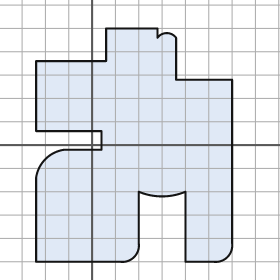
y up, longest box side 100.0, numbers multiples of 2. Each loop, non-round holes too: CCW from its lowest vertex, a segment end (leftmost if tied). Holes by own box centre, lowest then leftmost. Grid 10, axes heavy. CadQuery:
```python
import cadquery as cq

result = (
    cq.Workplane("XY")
    .moveTo(-24.0, -50.0)
    .lineTo(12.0, -50.0)
    .threePointArc((18.0, -48.0), (20.0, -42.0))
    .lineTo(20.0, -20.0)
    .threePointArc((30.0, -22.0), (40.0, -20.0))
    .lineTo(40.0, -50.0)
    .lineTo(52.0, -50.0)
    .threePointArc((58.0, -48.0), (60.0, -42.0))
    .lineTo(60.0, 28.0)
    .lineTo(36.0, 28.0)
    .lineTo(36.0, 46.0)
    .threePointArc((32.0, 48.0), (28.0, 46.0))
    .lineTo(28.0, 50.0)
    .lineTo(6.0, 50.0)
    .lineTo(6.0, 36.0)
    .lineTo(-24.0, 36.0)
    .lineTo(-24.0, 6.0)
    .lineTo(4.0, 6.0)
    .lineTo(4.0, -2.0)
    .lineTo(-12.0, -2.0)
    .threePointArc((-20.0, -6.0), (-24.0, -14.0))
    .close()
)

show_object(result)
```